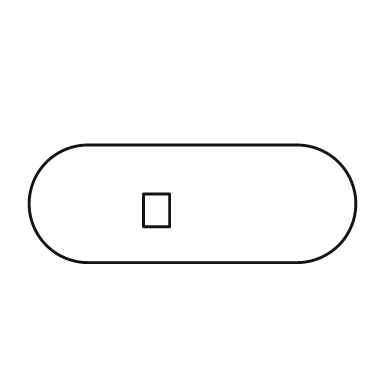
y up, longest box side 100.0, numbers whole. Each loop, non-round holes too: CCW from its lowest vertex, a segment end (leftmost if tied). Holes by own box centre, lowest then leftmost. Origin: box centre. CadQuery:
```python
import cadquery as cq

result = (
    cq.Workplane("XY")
    .moveTo(-32.0, -18.0)
    .lineTo(32.0, -18.0)
    .threePointArc((50.0, 0.0), (32.0, 18.0))
    .lineTo(-32.0, 18.0)
    .threePointArc((-50.0, 0.0), (-32.0, -18.0))
    .close()
    .moveTo(-15.0, -7.0)
    .lineTo(-7.0, -7.0)
    .lineTo(-7.0, 3.0)
    .lineTo(-15.0, 3.0)
    .close()
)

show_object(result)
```